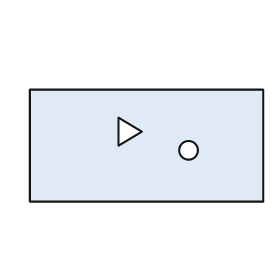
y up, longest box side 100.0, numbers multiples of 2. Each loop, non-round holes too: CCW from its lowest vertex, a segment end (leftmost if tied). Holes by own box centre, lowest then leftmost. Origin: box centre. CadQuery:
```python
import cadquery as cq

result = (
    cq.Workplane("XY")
    .moveTo(-50.0, -24.0)
    .lineTo(50.0, -24.0)
    .lineTo(50.0, 24.0)
    .lineTo(-50.0, 24.0)
    .close()
    .moveTo(18.0, -2.0)
    .circle(4.0)
    .moveTo(-12.0, 0.0)
    .lineTo(-2.0, 6.0)
    .lineTo(-12.0, 12.0)
    .close()
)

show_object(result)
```